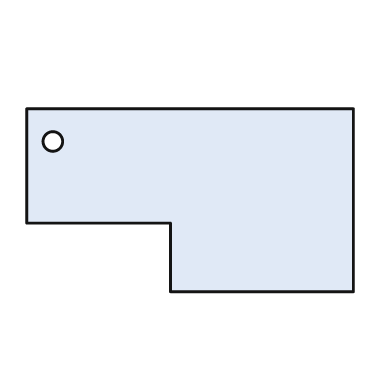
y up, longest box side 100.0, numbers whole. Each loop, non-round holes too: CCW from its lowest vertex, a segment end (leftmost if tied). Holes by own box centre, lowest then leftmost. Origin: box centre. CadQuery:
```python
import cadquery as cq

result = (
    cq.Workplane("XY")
    .moveTo(-6.0, -28.0)
    .lineTo(50.0, -28.0)
    .lineTo(50.0, 28.0)
    .lineTo(-50.0, 28.0)
    .lineTo(-50.0, -7.0)
    .lineTo(-6.0, -7.0)
    .close()
    .moveTo(-42.0, 18.0)
    .circle(3.0)
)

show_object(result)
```